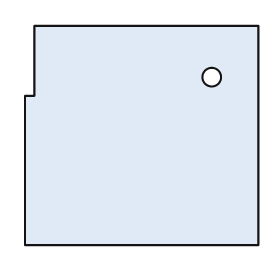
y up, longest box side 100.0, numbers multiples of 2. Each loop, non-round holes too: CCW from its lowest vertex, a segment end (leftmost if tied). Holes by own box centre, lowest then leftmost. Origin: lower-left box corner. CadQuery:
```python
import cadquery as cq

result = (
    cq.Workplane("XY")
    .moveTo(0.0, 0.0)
    .lineTo(100.0, 0.0)
    .lineTo(100.0, 94.0)
    .lineTo(4.0, 94.0)
    .lineTo(4.0, 64.0)
    .lineTo(0.0, 64.0)
    .close()
    .moveTo(80.0, 72.0)
    .circle(4.0)
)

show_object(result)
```